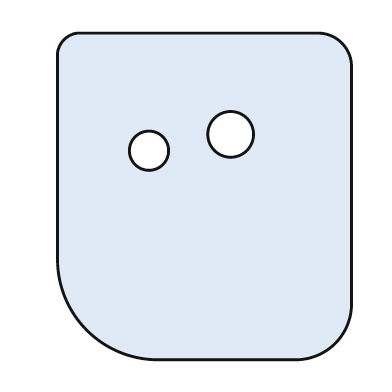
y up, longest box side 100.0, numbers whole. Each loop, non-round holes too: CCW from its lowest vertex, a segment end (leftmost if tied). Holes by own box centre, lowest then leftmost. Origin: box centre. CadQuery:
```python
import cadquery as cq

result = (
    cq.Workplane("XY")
    .moveTo(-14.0, -50.0)
    .lineTo(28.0, -50.0)
    .threePointArc((40.0, -45.0), (45.0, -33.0))
    .lineTo(45.0, 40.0)
    .threePointArc((42.0, 47.0), (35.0, 50.0))
    .lineTo(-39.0, 50.0)
    .threePointArc((-43.0, 48.0), (-45.0, 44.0))
    .lineTo(-45.0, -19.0)
    .threePointArc((-36.0, -41.0), (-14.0, -50.0))
    .close()
    .moveTo(-17.0, 14.0)
    .circle(6.0)
    .moveTo(8.0, 19.0)
    .circle(7.0)
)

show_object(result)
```